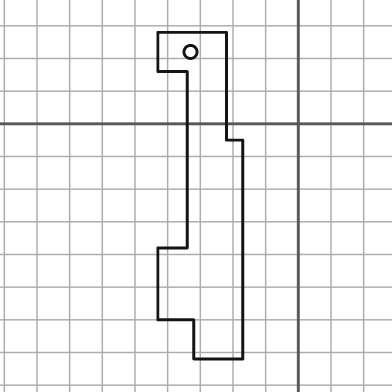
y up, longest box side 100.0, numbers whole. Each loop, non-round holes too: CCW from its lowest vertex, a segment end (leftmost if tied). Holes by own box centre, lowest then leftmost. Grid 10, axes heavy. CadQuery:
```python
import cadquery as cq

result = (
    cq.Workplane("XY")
    .moveTo(-32.0, -72.0)
    .lineTo(-17.0, -72.0)
    .lineTo(-17.0, -5.0)
    .lineTo(-22.0, -5.0)
    .lineTo(-22.0, 28.0)
    .lineTo(-43.0, 28.0)
    .lineTo(-43.0, 16.0)
    .lineTo(-34.0, 16.0)
    .lineTo(-34.0, -38.0)
    .lineTo(-43.0, -38.0)
    .lineTo(-43.0, -60.0)
    .lineTo(-32.0, -60.0)
    .close()
    .moveTo(-33.0, 22.0)
    .circle(2.0)
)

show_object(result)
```